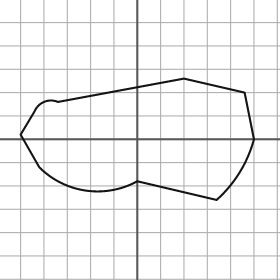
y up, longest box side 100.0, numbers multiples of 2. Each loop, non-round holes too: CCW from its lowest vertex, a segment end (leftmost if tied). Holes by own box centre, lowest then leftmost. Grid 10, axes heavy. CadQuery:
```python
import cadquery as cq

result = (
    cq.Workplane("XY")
    .moveTo(34.0, -26.0)
    .threePointArc((44.0, -14.0), (50.0, 0.0))
    .lineTo(46.0, 20.0)
    .lineTo(20.0, 26.0)
    .lineTo(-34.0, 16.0)
    .threePointArc((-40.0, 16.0), (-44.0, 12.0))
    .lineTo(-50.0, 2.0)
    .lineTo(-42.0, -12.0)
    .threePointArc((-22.0, -22.0), (0.0, -18.0))
    .close()
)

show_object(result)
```